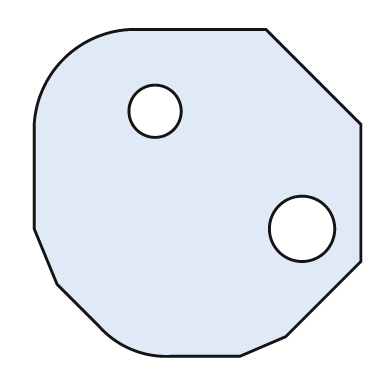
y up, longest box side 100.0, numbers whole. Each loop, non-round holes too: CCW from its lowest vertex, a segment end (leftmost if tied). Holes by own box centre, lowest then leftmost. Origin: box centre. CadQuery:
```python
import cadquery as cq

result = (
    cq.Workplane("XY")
    .moveTo(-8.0, -50.0)
    .lineTo(13.0, -50.0)
    .lineTo(27.0, -44.0)
    .lineTo(50.0, -21.0)
    .lineTo(50.0, 21.0)
    .lineTo(21.0, 50.0)
    .lineTo(-21.0, 50.0)
    .threePointArc((-41.0, 41.0), (-50.0, 21.0))
    .lineTo(-50.0, -11.0)
    .lineTo(-43.0, -28.0)
    .lineTo(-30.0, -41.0)
    .threePointArc((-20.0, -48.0), (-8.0, -50.0))
    .close()
    .moveTo(32.0, -11.0)
    .circle(10.0)
    .moveTo(-13.0, 25.0)
    .circle(8.0)
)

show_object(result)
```